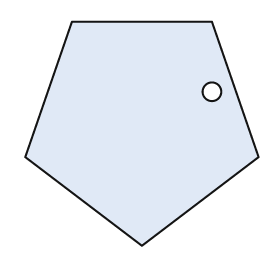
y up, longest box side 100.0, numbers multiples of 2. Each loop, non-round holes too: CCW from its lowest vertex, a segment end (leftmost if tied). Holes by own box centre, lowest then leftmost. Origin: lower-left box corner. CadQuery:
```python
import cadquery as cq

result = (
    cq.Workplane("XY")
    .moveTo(50.0, 0.0)
    .lineTo(100.0, 38.0)
    .lineTo(80.0, 96.0)
    .lineTo(20.0, 96.0)
    .lineTo(0.0, 38.0)
    .close()
    .moveTo(80.0, 66.0)
    .circle(4.0)
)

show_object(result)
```